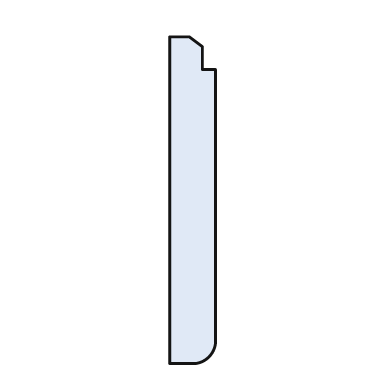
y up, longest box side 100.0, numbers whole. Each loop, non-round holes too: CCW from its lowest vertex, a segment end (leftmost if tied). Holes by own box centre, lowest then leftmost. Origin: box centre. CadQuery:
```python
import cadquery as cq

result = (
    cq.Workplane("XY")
    .moveTo(-7.0, -50.0)
    .lineTo(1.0, -50.0)
    .threePointArc((5.0, -48.0), (7.0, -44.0))
    .lineTo(7.0, 40.0)
    .lineTo(3.0, 40.0)
    .lineTo(3.0, 47.0)
    .lineTo(-1.0, 50.0)
    .lineTo(-7.0, 50.0)
    .close()
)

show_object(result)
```